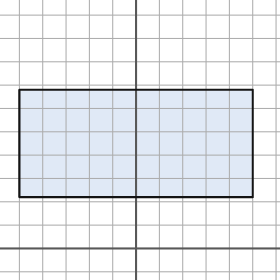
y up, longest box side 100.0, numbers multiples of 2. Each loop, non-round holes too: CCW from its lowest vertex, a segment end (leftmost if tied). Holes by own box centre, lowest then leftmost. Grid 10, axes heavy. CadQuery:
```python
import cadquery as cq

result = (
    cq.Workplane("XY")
    .moveTo(-50.0, 22.0)
    .lineTo(50.0, 22.0)
    .lineTo(50.0, 68.0)
    .lineTo(-50.0, 68.0)
    .close()
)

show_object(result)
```